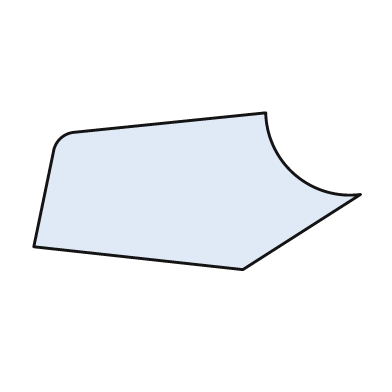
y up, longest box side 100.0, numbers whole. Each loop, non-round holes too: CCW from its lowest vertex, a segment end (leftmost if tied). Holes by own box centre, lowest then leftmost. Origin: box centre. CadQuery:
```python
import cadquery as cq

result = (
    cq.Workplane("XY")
    .moveTo(14.0, -24.0)
    .lineTo(50.0, -1.0)
    .threePointArc((30.0, 5.0), (21.0, 24.0))
    .lineTo(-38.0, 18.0)
    .threePointArc((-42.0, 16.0), (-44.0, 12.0))
    .lineTo(-50.0, -17.0)
    .close()
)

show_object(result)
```